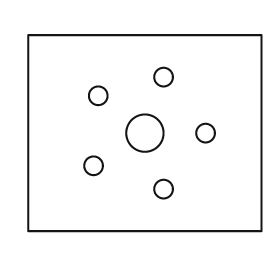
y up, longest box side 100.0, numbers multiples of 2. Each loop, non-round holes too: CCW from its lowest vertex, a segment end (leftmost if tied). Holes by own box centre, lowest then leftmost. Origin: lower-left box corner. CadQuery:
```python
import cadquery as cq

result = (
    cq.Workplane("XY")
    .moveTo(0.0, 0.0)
    .lineTo(100.0, 0.0)
    .lineTo(100.0, 84.0)
    .lineTo(0.0, 84.0)
    .close()
    .moveTo(58.0, 18.0)
    .circle(4.0)
    .moveTo(28.0, 28.0)
    .circle(4.0)
    .moveTo(50.0, 42.0)
    .circle(8.0)
    .moveTo(76.0, 42.0)
    .circle(4.0)
    .moveTo(30.0, 58.0)
    .circle(4.0)
    .moveTo(58.0, 66.0)
    .circle(4.0)
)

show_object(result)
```